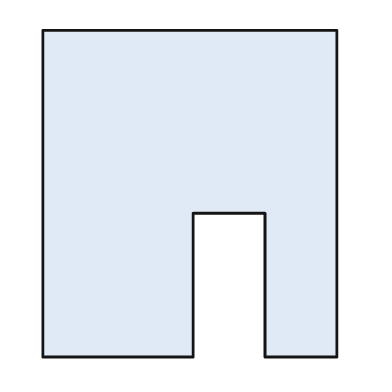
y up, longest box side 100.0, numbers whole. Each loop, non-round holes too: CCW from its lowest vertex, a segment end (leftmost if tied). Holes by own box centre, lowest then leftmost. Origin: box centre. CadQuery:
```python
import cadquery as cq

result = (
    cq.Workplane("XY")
    .moveTo(-45.0, -50.0)
    .lineTo(1.0, -50.0)
    .lineTo(1.0, -6.0)
    .lineTo(23.0, -6.0)
    .lineTo(23.0, -50.0)
    .lineTo(45.0, -50.0)
    .lineTo(45.0, 50.0)
    .lineTo(-45.0, 50.0)
    .close()
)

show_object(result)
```